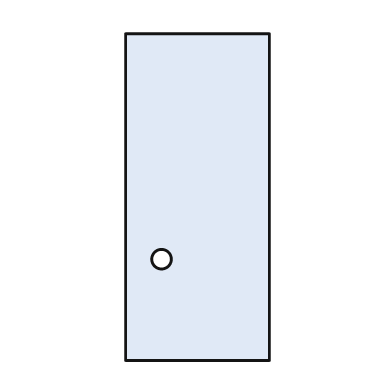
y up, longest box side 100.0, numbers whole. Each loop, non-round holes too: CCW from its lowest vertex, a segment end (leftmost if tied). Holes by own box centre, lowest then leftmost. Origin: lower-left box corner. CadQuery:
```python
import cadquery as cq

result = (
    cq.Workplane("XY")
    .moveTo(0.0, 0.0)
    .lineTo(44.0, 0.0)
    .lineTo(44.0, 100.0)
    .lineTo(0.0, 100.0)
    .close()
    .moveTo(11.0, 31.0)
    .circle(3.0)
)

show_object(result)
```